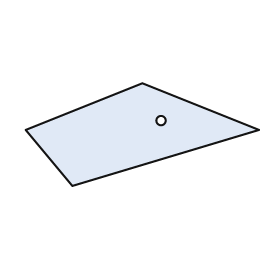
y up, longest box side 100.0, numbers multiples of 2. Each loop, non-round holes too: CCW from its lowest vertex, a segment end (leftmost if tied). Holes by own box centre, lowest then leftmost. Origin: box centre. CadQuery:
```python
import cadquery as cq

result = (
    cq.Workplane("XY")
    .moveTo(-30.0, -22.0)
    .lineTo(50.0, 2.0)
    .lineTo(0.0, 22.0)
    .lineTo(-50.0, 2.0)
    .close()
    .moveTo(8.0, 6.0)
    .circle(2.0)
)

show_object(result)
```